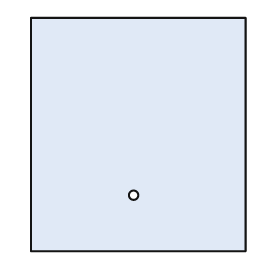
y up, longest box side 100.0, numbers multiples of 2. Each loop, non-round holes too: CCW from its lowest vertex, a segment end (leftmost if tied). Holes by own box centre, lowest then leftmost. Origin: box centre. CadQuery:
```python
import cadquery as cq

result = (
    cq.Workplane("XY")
    .moveTo(-46.0, -50.0)
    .lineTo(46.0, -50.0)
    .lineTo(46.0, 50.0)
    .lineTo(-46.0, 50.0)
    .close()
    .moveTo(-2.0, -26.0)
    .circle(2.0)
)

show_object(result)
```